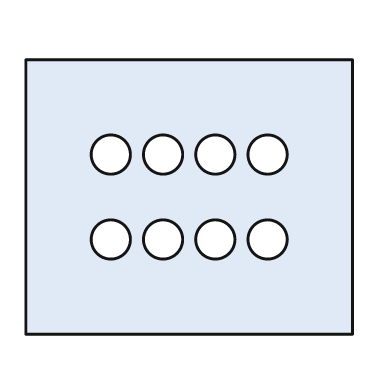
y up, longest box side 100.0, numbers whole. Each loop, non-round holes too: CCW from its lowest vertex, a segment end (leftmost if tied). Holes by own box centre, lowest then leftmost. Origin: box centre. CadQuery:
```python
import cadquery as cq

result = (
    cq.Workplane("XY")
    .moveTo(-50.0, -42.0)
    .lineTo(50.0, -42.0)
    .lineTo(50.0, 42.0)
    .lineTo(-50.0, 42.0)
    .close()
    .moveTo(-24.0, -13.0)
    .circle(6.0)
    .moveTo(-8.0, -13.0)
    .circle(6.0)
    .moveTo(8.0, -13.0)
    .circle(6.0)
    .moveTo(24.0, -13.0)
    .circle(6.0)
    .moveTo(-24.0, 13.0)
    .circle(6.0)
    .moveTo(-8.0, 13.0)
    .circle(6.0)
    .moveTo(8.0, 13.0)
    .circle(6.0)
    .moveTo(24.0, 13.0)
    .circle(6.0)
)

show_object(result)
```